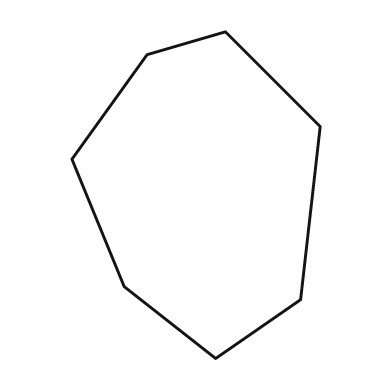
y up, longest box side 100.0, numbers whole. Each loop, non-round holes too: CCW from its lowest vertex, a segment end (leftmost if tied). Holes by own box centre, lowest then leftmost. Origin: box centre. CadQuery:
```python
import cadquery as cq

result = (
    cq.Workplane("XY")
    .moveTo(6.0, -50.0)
    .lineTo(32.0, -32.0)
    .lineTo(38.0, 21.0)
    .lineTo(9.0, 50.0)
    .lineTo(-15.0, 43.0)
    .lineTo(-38.0, 11.0)
    .lineTo(-22.0, -28.0)
    .close()
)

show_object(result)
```